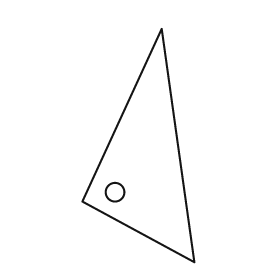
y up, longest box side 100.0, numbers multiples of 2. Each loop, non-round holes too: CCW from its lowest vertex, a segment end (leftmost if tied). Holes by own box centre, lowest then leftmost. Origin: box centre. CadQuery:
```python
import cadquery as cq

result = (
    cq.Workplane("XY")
    .moveTo(24.0, -50.0)
    .lineTo(10.0, 50.0)
    .lineTo(-24.0, -24.0)
    .close()
    .moveTo(-10.0, -20.0)
    .circle(4.0)
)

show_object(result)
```